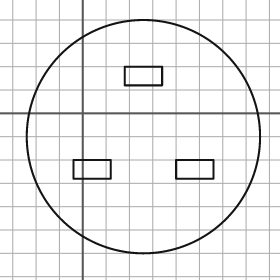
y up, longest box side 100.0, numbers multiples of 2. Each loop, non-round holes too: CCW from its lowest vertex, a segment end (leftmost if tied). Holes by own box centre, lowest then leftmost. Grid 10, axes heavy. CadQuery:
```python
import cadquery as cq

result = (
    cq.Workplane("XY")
    .moveTo(26.0, -10.0)
    .circle(50.0)
    .moveTo(-4.0, -28.0)
    .lineTo(12.0, -28.0)
    .lineTo(12.0, -20.0)
    .lineTo(-4.0, -20.0)
    .close()
    .moveTo(40.0, -28.0)
    .lineTo(56.0, -28.0)
    .lineTo(56.0, -20.0)
    .lineTo(40.0, -20.0)
    .close()
    .moveTo(18.0, 12.0)
    .lineTo(34.0, 12.0)
    .lineTo(34.0, 20.0)
    .lineTo(18.0, 20.0)
    .close()
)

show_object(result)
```